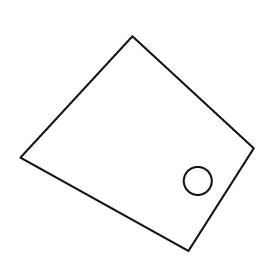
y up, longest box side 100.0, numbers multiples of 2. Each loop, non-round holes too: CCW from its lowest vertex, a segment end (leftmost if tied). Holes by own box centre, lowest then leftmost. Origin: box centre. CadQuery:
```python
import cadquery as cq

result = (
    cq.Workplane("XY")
    .moveTo(22.0, -46.0)
    .lineTo(50.0, -2.0)
    .lineTo(-2.0, 46.0)
    .lineTo(-50.0, -6.0)
    .close()
    .moveTo(26.0, -16.0)
    .circle(6.0)
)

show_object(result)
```